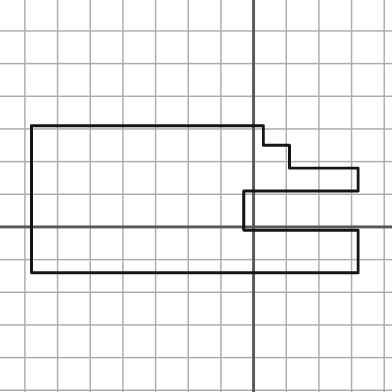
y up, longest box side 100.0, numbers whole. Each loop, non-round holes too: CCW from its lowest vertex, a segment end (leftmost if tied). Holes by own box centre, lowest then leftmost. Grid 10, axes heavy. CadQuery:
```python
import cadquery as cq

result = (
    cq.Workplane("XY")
    .moveTo(-68.0, -14.0)
    .lineTo(32.0, -14.0)
    .lineTo(32.0, -1.0)
    .lineTo(-3.0, -1.0)
    .lineTo(-3.0, 11.0)
    .lineTo(32.0, 11.0)
    .lineTo(32.0, 18.0)
    .lineTo(11.0, 18.0)
    .lineTo(11.0, 25.0)
    .lineTo(3.0, 25.0)
    .lineTo(3.0, 31.0)
    .lineTo(-68.0, 31.0)
    .close()
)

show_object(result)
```